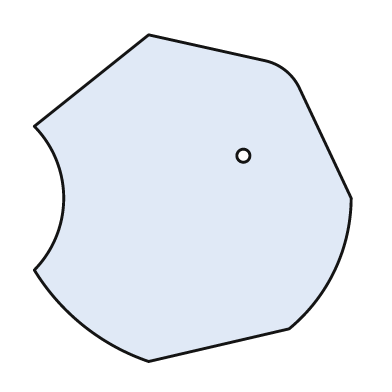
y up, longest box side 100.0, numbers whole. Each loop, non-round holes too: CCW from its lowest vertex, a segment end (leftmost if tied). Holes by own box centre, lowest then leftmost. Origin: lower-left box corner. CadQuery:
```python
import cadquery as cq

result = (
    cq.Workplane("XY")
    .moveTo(35.0, 0.0)
    .lineTo(78.0, 10.0)
    .threePointArc((92.0, 28.0), (97.0, 50.0))
    .lineTo(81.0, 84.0)
    .threePointArc((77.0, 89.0), (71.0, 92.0))
    .lineTo(35.0, 100.0)
    .lineTo(0.0, 72.0)
    .threePointArc((9.0, 50.0), (0.0, 28.0))
    .threePointArc((15.0, 11.0), (35.0, 0.0))
    .close()
    .moveTo(64.0, 63.0)
    .circle(2.0)
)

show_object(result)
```